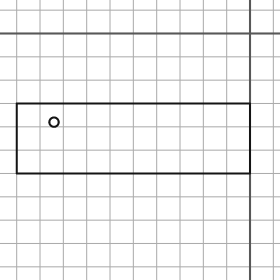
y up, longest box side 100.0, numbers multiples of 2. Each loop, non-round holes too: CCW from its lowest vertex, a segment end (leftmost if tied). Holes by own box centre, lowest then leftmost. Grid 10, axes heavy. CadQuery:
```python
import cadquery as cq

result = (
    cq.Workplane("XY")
    .moveTo(-100.0, -60.0)
    .lineTo(0.0, -60.0)
    .lineTo(0.0, -30.0)
    .lineTo(-100.0, -30.0)
    .close()
    .moveTo(-84.0, -38.0)
    .circle(2.0)
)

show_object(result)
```